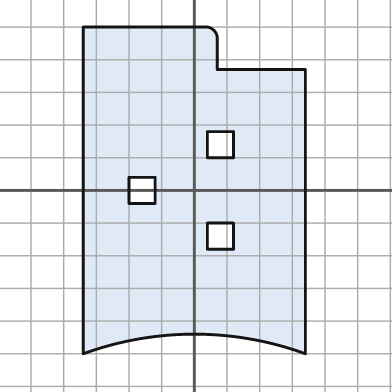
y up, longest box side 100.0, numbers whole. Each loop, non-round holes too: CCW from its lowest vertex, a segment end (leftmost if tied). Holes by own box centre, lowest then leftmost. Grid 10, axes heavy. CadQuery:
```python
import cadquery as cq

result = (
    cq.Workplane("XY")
    .moveTo(-34.0, -50.0)
    .threePointArc((0.0, -44.0), (34.0, -50.0))
    .lineTo(34.0, 37.0)
    .lineTo(7.0, 37.0)
    .lineTo(7.0, 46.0)
    .threePointArc((6.0, 49.0), (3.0, 50.0))
    .lineTo(-34.0, 50.0)
    .close()
    .moveTo(4.0, -18.0)
    .lineTo(12.0, -18.0)
    .lineTo(12.0, -10.0)
    .lineTo(4.0, -10.0)
    .close()
    .moveTo(-20.0, -4.0)
    .lineTo(-12.0, -4.0)
    .lineTo(-12.0, 4.0)
    .lineTo(-20.0, 4.0)
    .close()
    .moveTo(4.0, 10.0)
    .lineTo(12.0, 10.0)
    .lineTo(12.0, 18.0)
    .lineTo(4.0, 18.0)
    .close()
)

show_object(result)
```